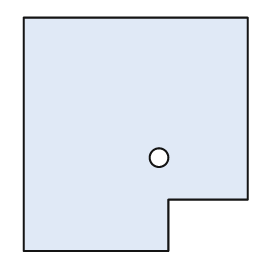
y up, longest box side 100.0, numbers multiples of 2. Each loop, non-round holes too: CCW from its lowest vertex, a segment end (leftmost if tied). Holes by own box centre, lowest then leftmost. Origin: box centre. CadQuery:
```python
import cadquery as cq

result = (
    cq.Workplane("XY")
    .moveTo(-48.0, -50.0)
    .lineTo(14.0, -50.0)
    .lineTo(14.0, -28.0)
    .lineTo(48.0, -28.0)
    .lineTo(48.0, 50.0)
    .lineTo(-48.0, 50.0)
    .close()
    .moveTo(10.0, -10.0)
    .circle(4.0)
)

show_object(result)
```